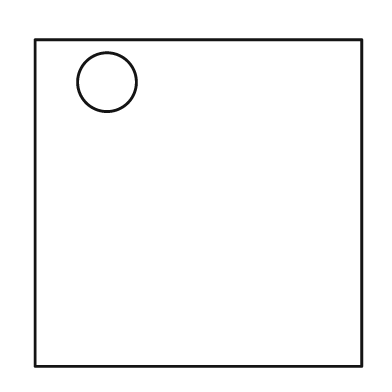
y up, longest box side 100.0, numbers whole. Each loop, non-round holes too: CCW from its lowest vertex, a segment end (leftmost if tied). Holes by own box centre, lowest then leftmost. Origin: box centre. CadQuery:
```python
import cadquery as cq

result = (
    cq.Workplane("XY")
    .moveTo(-50.0, -50.0)
    .lineTo(50.0, -50.0)
    .lineTo(50.0, 50.0)
    .lineTo(-50.0, 50.0)
    .close()
    .moveTo(-28.0, 37.0)
    .circle(9.0)
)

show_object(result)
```